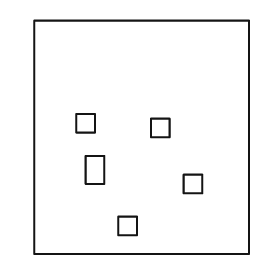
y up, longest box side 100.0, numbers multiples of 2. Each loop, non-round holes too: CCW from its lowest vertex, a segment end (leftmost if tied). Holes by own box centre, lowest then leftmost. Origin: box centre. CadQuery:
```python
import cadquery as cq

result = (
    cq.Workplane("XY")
    .moveTo(-46.0, -50.0)
    .lineTo(46.0, -50.0)
    .lineTo(46.0, 50.0)
    .lineTo(-46.0, 50.0)
    .close()
    .moveTo(-10.0, -42.0)
    .lineTo(-2.0, -42.0)
    .lineTo(-2.0, -34.0)
    .lineTo(-10.0, -34.0)
    .close()
    .moveTo(18.0, -24.0)
    .lineTo(26.0, -24.0)
    .lineTo(26.0, -16.0)
    .lineTo(18.0, -16.0)
    .close()
    .moveTo(-24.0, -20.0)
    .lineTo(-16.0, -20.0)
    .lineTo(-16.0, -8.0)
    .lineTo(-24.0, -8.0)
    .close()
    .moveTo(4.0, 0.0)
    .lineTo(12.0, 0.0)
    .lineTo(12.0, 8.0)
    .lineTo(4.0, 8.0)
    .close()
    .moveTo(-28.0, 2.0)
    .lineTo(-20.0, 2.0)
    .lineTo(-20.0, 10.0)
    .lineTo(-28.0, 10.0)
    .close()
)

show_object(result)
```